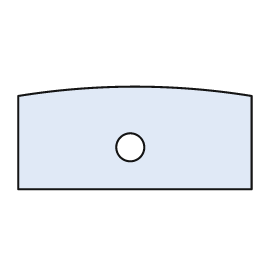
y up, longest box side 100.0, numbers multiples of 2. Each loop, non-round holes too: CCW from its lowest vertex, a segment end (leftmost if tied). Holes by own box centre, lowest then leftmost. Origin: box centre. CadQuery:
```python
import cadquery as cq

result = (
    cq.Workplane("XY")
    .moveTo(-50.0, -22.0)
    .lineTo(50.0, -22.0)
    .lineTo(50.0, 18.0)
    .threePointArc((0.0, 22.0), (-50.0, 18.0))
    .close()
    .moveTo(-2.0, -4.0)
    .circle(6.0)
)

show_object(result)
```